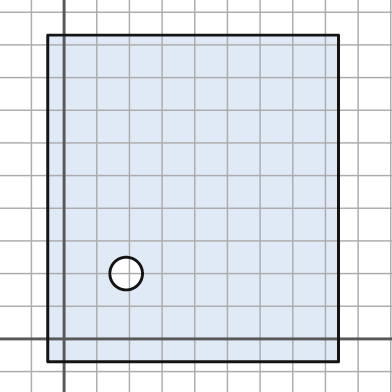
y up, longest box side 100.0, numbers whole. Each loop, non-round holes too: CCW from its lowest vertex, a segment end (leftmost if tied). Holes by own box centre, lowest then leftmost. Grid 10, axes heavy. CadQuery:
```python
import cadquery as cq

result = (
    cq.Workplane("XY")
    .moveTo(-5.0, -7.0)
    .lineTo(84.0, -7.0)
    .lineTo(84.0, 93.0)
    .lineTo(-5.0, 93.0)
    .close()
    .moveTo(19.0, 20.0)
    .circle(5.0)
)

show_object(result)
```